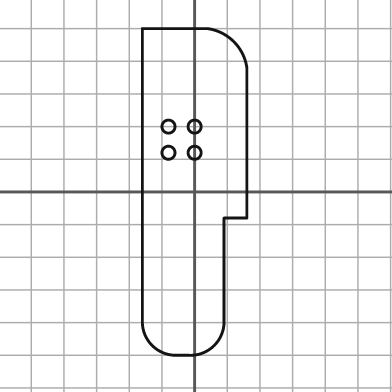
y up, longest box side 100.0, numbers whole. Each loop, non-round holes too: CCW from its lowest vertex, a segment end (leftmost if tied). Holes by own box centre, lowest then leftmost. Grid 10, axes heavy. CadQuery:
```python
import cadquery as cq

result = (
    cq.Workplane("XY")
    .moveTo(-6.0, -50.0)
    .lineTo(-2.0, -50.0)
    .threePointArc((6.0, -47.0), (9.0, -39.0))
    .lineTo(9.0, -8.0)
    .lineTo(16.0, -8.0)
    .lineTo(16.0, 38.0)
    .threePointArc((12.0, 46.0), (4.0, 50.0))
    .lineTo(-16.0, 50.0)
    .lineTo(-16.0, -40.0)
    .threePointArc((-13.0, -47.0), (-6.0, -50.0))
    .close()
    .moveTo(-8.0, 12.0)
    .circle(2.0)
    .moveTo(0.0, 12.0)
    .circle(2.0)
    .moveTo(-8.0, 20.0)
    .circle(2.0)
    .moveTo(0.0, 20.0)
    .circle(2.0)
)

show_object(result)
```